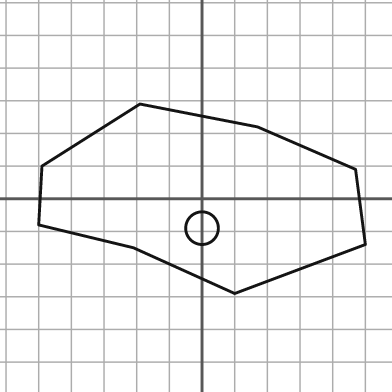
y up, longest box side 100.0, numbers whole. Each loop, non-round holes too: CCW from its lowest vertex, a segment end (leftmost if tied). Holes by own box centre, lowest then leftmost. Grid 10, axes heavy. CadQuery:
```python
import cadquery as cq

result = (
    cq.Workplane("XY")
    .moveTo(10.0, -29.0)
    .lineTo(50.0, -14.0)
    .lineTo(47.0, 9.0)
    .lineTo(17.0, 22.0)
    .lineTo(-19.0, 29.0)
    .lineTo(-49.0, 10.0)
    .lineTo(-50.0, -8.0)
    .lineTo(-21.0, -15.0)
    .close()
    .moveTo(0.0, -9.0)
    .circle(5.0)
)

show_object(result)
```